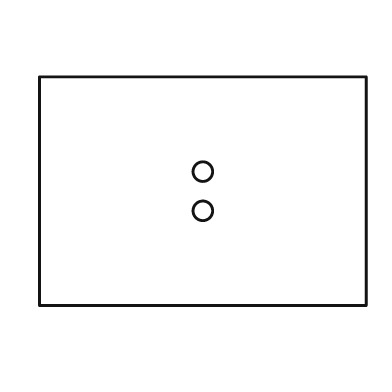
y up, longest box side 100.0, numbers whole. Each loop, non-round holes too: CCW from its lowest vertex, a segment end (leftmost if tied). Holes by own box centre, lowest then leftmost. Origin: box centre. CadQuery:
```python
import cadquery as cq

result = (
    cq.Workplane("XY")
    .moveTo(-50.0, -35.0)
    .lineTo(50.0, -35.0)
    .lineTo(50.0, 35.0)
    .lineTo(-50.0, 35.0)
    .close()
    .moveTo(0.0, -6.0)
    .circle(3.0)
    .moveTo(0.0, 6.0)
    .circle(3.0)
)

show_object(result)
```